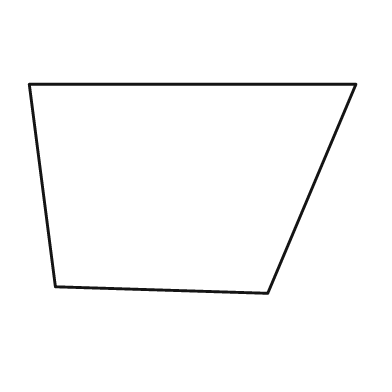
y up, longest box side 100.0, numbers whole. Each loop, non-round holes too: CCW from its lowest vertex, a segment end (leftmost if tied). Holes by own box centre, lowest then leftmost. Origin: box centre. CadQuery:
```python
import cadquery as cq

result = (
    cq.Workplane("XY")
    .moveTo(23.0, -32.0)
    .lineTo(50.0, 32.0)
    .lineTo(-50.0, 32.0)
    .lineTo(-42.0, -30.0)
    .close()
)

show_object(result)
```